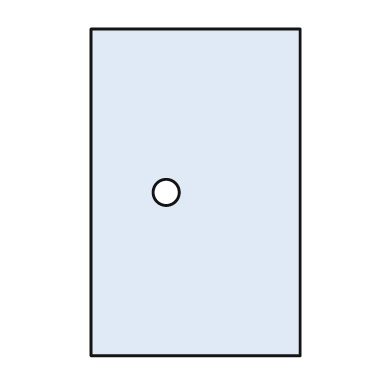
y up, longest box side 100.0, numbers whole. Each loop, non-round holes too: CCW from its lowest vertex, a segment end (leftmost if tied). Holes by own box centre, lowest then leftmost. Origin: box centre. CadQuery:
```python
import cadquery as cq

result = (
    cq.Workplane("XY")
    .moveTo(-32.0, -50.0)
    .lineTo(32.0, -50.0)
    .lineTo(32.0, 50.0)
    .lineTo(-32.0, 50.0)
    .close()
    .moveTo(-9.0, 0.0)
    .circle(4.0)
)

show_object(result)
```